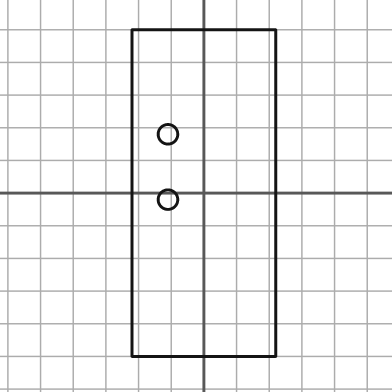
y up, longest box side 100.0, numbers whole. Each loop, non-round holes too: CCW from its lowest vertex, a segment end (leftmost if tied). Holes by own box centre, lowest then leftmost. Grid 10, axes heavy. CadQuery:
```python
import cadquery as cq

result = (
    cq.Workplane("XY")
    .moveTo(-22.0, -50.0)
    .lineTo(22.0, -50.0)
    .lineTo(22.0, 50.0)
    .lineTo(-22.0, 50.0)
    .close()
    .moveTo(-11.0, -2.0)
    .circle(3.0)
    .moveTo(-11.0, 18.0)
    .circle(3.0)
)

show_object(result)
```